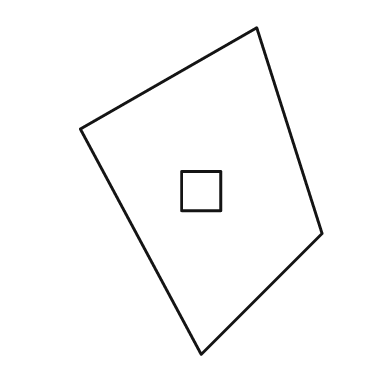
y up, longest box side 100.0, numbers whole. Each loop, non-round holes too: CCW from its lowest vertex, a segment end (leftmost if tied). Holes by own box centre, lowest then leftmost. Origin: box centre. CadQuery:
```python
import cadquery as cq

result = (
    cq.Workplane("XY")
    .moveTo(0.0, -50.0)
    .lineTo(37.0, -13.0)
    .lineTo(17.0, 50.0)
    .lineTo(-37.0, 19.0)
    .close()
    .moveTo(-6.0, -6.0)
    .lineTo(6.0, -6.0)
    .lineTo(6.0, 6.0)
    .lineTo(-6.0, 6.0)
    .close()
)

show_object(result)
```